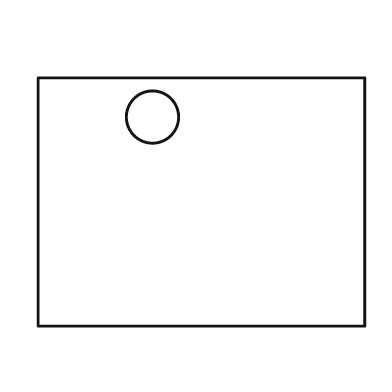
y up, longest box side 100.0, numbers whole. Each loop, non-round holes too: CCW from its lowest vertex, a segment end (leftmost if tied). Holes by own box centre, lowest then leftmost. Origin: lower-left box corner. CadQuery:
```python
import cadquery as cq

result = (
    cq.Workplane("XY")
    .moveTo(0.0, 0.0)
    .lineTo(100.0, 0.0)
    .lineTo(100.0, 76.0)
    .lineTo(0.0, 76.0)
    .close()
    .moveTo(35.0, 64.0)
    .circle(8.0)
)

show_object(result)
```